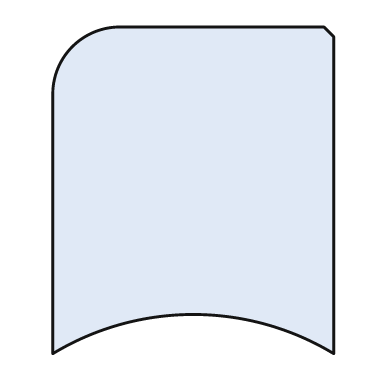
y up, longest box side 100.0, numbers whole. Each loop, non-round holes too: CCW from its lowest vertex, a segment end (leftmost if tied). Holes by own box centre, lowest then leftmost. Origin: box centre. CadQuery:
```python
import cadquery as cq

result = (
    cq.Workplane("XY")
    .moveTo(-43.0, -50.0)
    .threePointArc((0.0, -38.0), (43.0, -50.0))
    .lineTo(43.0, 47.0)
    .lineTo(40.0, 50.0)
    .lineTo(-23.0, 50.0)
    .threePointArc((-37.0, 44.0), (-43.0, 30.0))
    .close()
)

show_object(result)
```